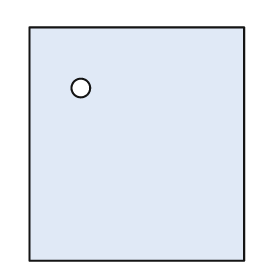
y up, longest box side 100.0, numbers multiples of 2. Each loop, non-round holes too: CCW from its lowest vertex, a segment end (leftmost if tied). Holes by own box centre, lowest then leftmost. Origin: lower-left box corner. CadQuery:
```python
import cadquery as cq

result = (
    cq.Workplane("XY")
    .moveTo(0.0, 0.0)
    .lineTo(92.0, 0.0)
    .lineTo(92.0, 100.0)
    .lineTo(0.0, 100.0)
    .close()
    .moveTo(22.0, 74.0)
    .circle(4.0)
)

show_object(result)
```